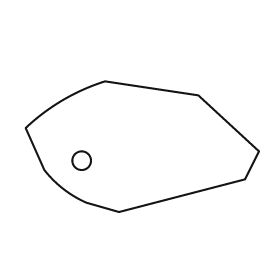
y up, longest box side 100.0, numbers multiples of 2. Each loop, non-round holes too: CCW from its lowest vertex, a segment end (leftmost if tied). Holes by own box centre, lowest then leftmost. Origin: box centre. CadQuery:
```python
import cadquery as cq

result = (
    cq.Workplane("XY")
    .moveTo(-10.0, -28.0)
    .lineTo(44.0, -14.0)
    .lineTo(50.0, -2.0)
    .lineTo(24.0, 22.0)
    .lineTo(-16.0, 28.0)
    .threePointArc((-34.0, 20.0), (-50.0, 8.0))
    .lineTo(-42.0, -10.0)
    .threePointArc((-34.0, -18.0), (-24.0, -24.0))
    .close()
    .moveTo(-26.0, -6.0)
    .circle(4.0)
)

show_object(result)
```